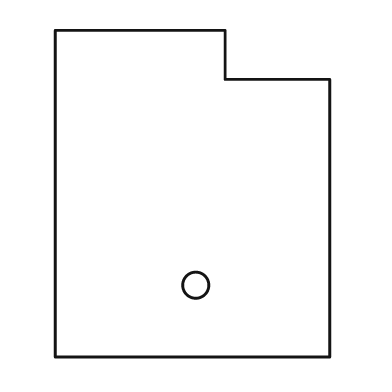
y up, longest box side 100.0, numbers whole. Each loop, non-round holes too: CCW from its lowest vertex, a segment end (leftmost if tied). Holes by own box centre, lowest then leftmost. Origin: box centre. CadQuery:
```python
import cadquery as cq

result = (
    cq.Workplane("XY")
    .moveTo(-42.0, -50.0)
    .lineTo(42.0, -50.0)
    .lineTo(42.0, 35.0)
    .lineTo(10.0, 35.0)
    .lineTo(10.0, 50.0)
    .lineTo(-42.0, 50.0)
    .close()
    .moveTo(1.0, -28.0)
    .circle(4.0)
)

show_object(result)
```